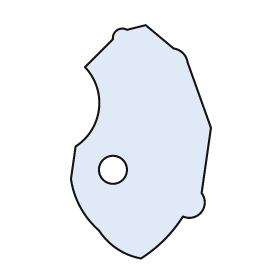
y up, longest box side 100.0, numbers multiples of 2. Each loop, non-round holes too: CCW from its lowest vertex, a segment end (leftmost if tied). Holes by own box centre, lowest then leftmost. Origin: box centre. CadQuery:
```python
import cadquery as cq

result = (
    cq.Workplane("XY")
    .moveTo(0.0, -50.0)
    .threePointArc((10.0, -42.0), (18.0, -32.0))
    .threePointArc((26.0, -30.0), (26.0, -22.0))
    .lineTo(30.0, 6.0)
    .lineTo(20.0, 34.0)
    .threePointArc((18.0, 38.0), (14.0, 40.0))
    .lineTo(2.0, 50.0)
    .lineTo(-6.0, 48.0)
    .threePointArc((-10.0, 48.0), (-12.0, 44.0))
    .lineTo(-24.0, 32.0)
    .threePointArc((-18.0, 14.0), (-28.0, -2.0))
    .lineTo(-30.0, -16.0)
    .threePointArc((-26.0, -28.0), (-18.0, -38.0))
    .threePointArc((-10.0, -46.0), (0.0, -50.0))
    .close()
    .moveTo(-12.0, -12.0)
    .circle(6.0)
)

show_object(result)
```